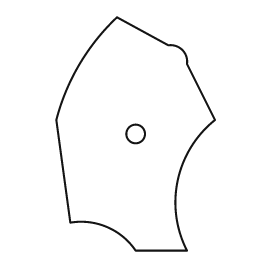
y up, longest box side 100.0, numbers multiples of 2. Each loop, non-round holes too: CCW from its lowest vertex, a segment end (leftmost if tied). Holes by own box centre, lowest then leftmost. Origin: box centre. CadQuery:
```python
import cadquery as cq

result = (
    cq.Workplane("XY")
    .moveTo(0.0, -50.0)
    .lineTo(22.0, -50.0)
    .threePointArc((18.0, -20.0), (34.0, 6.0))
    .lineTo(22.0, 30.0)
    .threePointArc((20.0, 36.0), (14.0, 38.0))
    .lineTo(-8.0, 50.0)
    .threePointArc((-24.0, 30.0), (-34.0, 6.0))
    .lineTo(-28.0, -38.0)
    .threePointArc((-12.0, -40.0), (0.0, -50.0))
    .close()
    .moveTo(0.0, 0.0)
    .circle(4.0)
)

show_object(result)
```